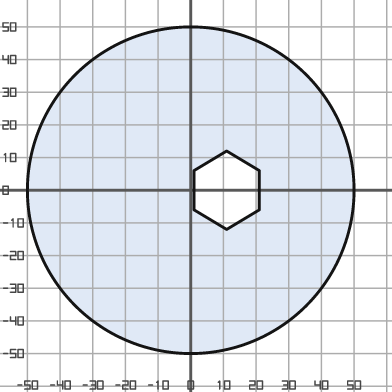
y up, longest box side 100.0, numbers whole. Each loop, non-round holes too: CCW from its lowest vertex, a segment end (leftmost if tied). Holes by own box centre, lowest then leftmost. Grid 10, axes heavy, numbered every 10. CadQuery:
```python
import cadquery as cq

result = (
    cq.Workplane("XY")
    .moveTo(0.0, 0.0)
    .circle(50.0)
    .moveTo(11.0, -12.0)
    .lineTo(21.0, -6.0)
    .lineTo(21.0, 6.0)
    .lineTo(11.0, 12.0)
    .lineTo(1.0, 6.0)
    .lineTo(1.0, -6.0)
    .close()
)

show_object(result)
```